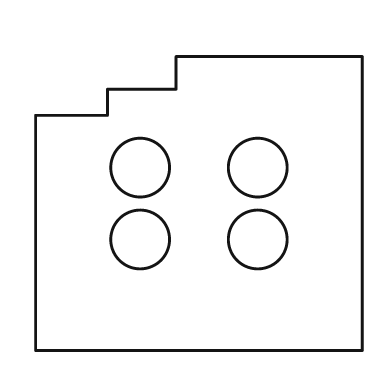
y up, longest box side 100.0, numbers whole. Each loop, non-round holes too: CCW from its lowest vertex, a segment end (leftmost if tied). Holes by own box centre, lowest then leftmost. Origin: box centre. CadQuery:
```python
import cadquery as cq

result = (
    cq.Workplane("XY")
    .moveTo(-50.0, -45.0)
    .lineTo(50.0, -45.0)
    .lineTo(50.0, 45.0)
    .lineTo(-7.0, 45.0)
    .lineTo(-7.0, 35.0)
    .lineTo(-28.0, 35.0)
    .lineTo(-28.0, 27.0)
    .lineTo(-50.0, 27.0)
    .close()
    .moveTo(-18.0, -11.0)
    .circle(9.0)
    .moveTo(18.0, -11.0)
    .circle(9.0)
    .moveTo(-18.0, 11.0)
    .circle(9.0)
    .moveTo(18.0, 11.0)
    .circle(9.0)
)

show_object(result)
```